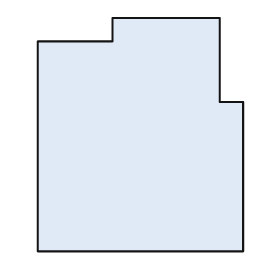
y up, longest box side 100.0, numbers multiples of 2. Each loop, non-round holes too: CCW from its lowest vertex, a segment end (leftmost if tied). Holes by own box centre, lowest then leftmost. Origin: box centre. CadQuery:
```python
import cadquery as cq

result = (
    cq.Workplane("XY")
    .moveTo(-44.0, -50.0)
    .lineTo(44.0, -50.0)
    .lineTo(44.0, 14.0)
    .lineTo(34.0, 14.0)
    .lineTo(34.0, 50.0)
    .lineTo(-12.0, 50.0)
    .lineTo(-12.0, 40.0)
    .lineTo(-44.0, 40.0)
    .close()
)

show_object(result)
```